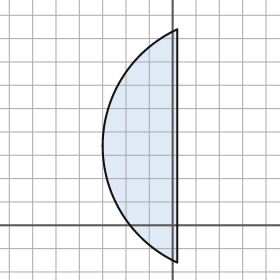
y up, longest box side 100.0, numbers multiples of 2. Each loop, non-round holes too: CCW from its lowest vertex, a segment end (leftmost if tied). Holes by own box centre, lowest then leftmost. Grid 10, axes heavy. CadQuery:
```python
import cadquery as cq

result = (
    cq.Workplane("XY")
    .moveTo(2.0, -16.0)
    .lineTo(2.0, 84.0)
    .threePointArc((-30.0, 34.0), (2.0, -16.0))
    .close()
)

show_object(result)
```